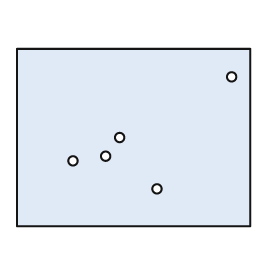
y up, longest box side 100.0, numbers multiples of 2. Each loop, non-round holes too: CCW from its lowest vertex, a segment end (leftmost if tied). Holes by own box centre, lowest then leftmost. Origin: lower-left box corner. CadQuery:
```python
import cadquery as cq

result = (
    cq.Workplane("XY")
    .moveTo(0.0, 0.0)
    .lineTo(100.0, 0.0)
    .lineTo(100.0, 76.0)
    .lineTo(0.0, 76.0)
    .close()
    .moveTo(60.0, 16.0)
    .circle(2.0)
    .moveTo(24.0, 28.0)
    .circle(2.0)
    .moveTo(38.0, 30.0)
    .circle(2.0)
    .moveTo(44.0, 38.0)
    .circle(2.0)
    .moveTo(92.0, 64.0)
    .circle(2.0)
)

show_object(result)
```